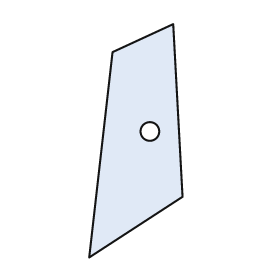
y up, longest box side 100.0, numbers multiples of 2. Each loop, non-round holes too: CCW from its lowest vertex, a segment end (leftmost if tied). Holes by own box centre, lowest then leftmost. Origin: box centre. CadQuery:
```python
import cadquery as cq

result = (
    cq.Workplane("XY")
    .moveTo(-20.0, -50.0)
    .lineTo(20.0, -24.0)
    .lineTo(16.0, 50.0)
    .lineTo(-10.0, 38.0)
    .close()
    .moveTo(6.0, 4.0)
    .circle(4.0)
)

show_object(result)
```